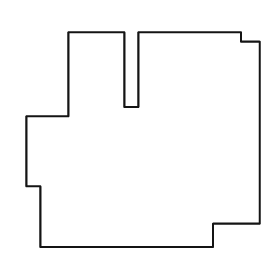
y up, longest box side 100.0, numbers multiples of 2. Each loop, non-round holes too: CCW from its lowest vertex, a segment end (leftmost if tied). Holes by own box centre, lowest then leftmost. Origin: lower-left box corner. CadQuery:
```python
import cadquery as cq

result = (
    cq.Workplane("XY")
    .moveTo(6.0, 0.0)
    .lineTo(80.0, 0.0)
    .lineTo(80.0, 10.0)
    .lineTo(100.0, 10.0)
    .lineTo(100.0, 88.0)
    .lineTo(92.0, 88.0)
    .lineTo(92.0, 92.0)
    .lineTo(48.0, 92.0)
    .lineTo(48.0, 60.0)
    .lineTo(42.0, 60.0)
    .lineTo(42.0, 92.0)
    .lineTo(18.0, 92.0)
    .lineTo(18.0, 56.0)
    .lineTo(0.0, 56.0)
    .lineTo(0.0, 26.0)
    .lineTo(6.0, 26.0)
    .close()
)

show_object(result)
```